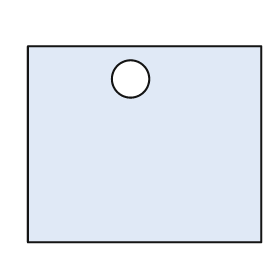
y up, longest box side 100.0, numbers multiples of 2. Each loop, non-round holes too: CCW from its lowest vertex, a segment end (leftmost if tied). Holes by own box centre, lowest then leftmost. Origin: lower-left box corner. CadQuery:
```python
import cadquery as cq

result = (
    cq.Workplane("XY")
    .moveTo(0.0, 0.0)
    .lineTo(100.0, 0.0)
    .lineTo(100.0, 84.0)
    .lineTo(0.0, 84.0)
    .close()
    .moveTo(44.0, 70.0)
    .circle(8.0)
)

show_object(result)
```